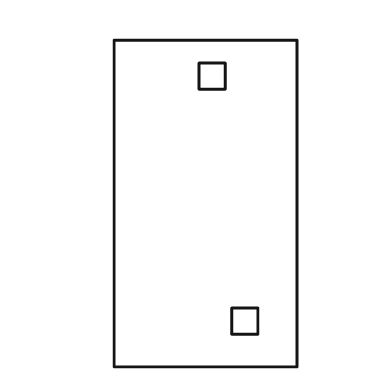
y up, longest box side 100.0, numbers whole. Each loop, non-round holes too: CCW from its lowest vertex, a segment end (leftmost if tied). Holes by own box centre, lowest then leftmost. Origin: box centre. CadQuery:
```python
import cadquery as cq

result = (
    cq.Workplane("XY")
    .moveTo(-28.0, -50.0)
    .lineTo(28.0, -50.0)
    .lineTo(28.0, 50.0)
    .lineTo(-28.0, 50.0)
    .close()
    .moveTo(8.0, -40.0)
    .lineTo(16.0, -40.0)
    .lineTo(16.0, -32.0)
    .lineTo(8.0, -32.0)
    .close()
    .moveTo(-2.0, 35.0)
    .lineTo(6.0, 35.0)
    .lineTo(6.0, 43.0)
    .lineTo(-2.0, 43.0)
    .close()
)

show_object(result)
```